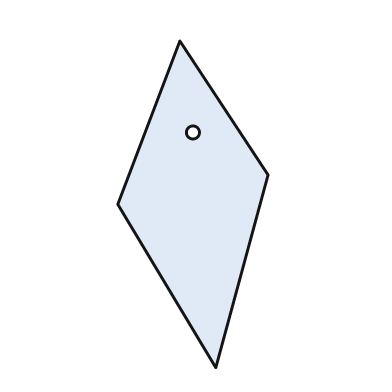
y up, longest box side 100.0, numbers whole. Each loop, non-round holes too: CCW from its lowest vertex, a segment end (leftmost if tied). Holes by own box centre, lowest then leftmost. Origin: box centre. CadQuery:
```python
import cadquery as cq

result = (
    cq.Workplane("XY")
    .moveTo(7.0, -50.0)
    .lineTo(23.0, 9.0)
    .lineTo(-4.0, 50.0)
    .lineTo(-23.0, 0.0)
    .close()
    .moveTo(0.0, 22.0)
    .circle(2.0)
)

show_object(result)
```